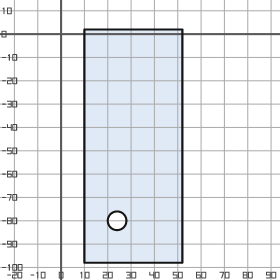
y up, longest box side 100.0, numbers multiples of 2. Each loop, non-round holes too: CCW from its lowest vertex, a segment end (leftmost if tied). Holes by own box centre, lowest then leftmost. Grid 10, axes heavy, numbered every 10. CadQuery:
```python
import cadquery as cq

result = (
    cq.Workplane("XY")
    .moveTo(10.0, -98.0)
    .lineTo(52.0, -98.0)
    .lineTo(52.0, 2.0)
    .lineTo(10.0, 2.0)
    .close()
    .moveTo(24.0, -80.0)
    .circle(4.0)
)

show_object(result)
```